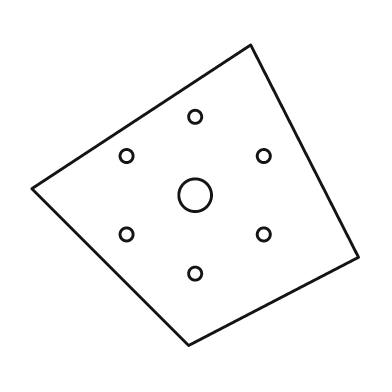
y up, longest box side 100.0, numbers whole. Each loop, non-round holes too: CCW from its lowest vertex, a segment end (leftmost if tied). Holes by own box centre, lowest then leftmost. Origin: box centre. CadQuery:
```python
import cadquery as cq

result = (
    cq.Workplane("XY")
    .moveTo(-2.0, -46.0)
    .lineTo(50.0, -19.0)
    .lineTo(17.0, 46.0)
    .lineTo(-50.0, 2.0)
    .close()
    .moveTo(0.0, -24.0)
    .circle(2.0)
    .moveTo(-21.0, -12.0)
    .circle(2.0)
    .moveTo(21.0, -12.0)
    .circle(2.0)
    .moveTo(0.0, 0.0)
    .circle(5.0)
    .moveTo(-21.0, 12.0)
    .circle(2.0)
    .moveTo(21.0, 12.0)
    .circle(2.0)
    .moveTo(0.0, 24.0)
    .circle(2.0)
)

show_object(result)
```